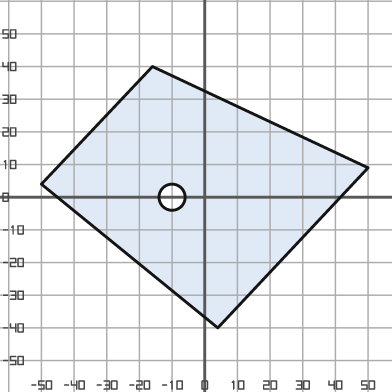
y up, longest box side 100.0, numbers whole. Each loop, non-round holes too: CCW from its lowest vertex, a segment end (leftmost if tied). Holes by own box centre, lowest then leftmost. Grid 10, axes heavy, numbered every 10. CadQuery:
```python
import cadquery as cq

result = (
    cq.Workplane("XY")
    .moveTo(4.0, -40.0)
    .lineTo(50.0, 9.0)
    .lineTo(-16.0, 40.0)
    .lineTo(-50.0, 4.0)
    .close()
    .moveTo(-10.0, 0.0)
    .circle(4.0)
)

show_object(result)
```